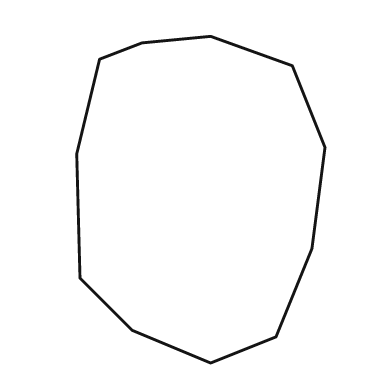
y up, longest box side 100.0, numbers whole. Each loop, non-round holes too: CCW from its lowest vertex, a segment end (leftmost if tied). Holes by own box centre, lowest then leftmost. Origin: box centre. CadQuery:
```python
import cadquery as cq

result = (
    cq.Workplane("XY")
    .moveTo(3.0, -50.0)
    .lineTo(23.0, -42.0)
    .lineTo(34.0, -15.0)
    .lineTo(38.0, 16.0)
    .lineTo(28.0, 41.0)
    .lineTo(3.0, 50.0)
    .lineTo(-18.0, 48.0)
    .lineTo(-31.0, 43.0)
    .lineTo(-38.0, 14.0)
    .lineTo(-37.0, -24.0)
    .lineTo(-21.0, -40.0)
    .close()
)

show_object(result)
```